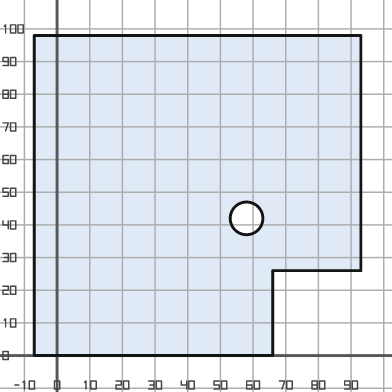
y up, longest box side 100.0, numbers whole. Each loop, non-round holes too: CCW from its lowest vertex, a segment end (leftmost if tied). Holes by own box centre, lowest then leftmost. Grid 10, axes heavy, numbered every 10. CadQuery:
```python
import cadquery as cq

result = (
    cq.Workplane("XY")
    .moveTo(-7.0, 0.0)
    .lineTo(66.0, 0.0)
    .lineTo(66.0, 26.0)
    .lineTo(93.0, 26.0)
    .lineTo(93.0, 98.0)
    .lineTo(-7.0, 98.0)
    .close()
    .moveTo(58.0, 42.0)
    .circle(5.0)
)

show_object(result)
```